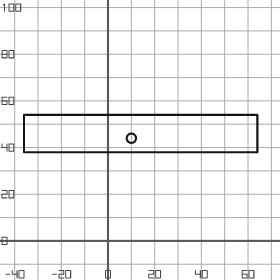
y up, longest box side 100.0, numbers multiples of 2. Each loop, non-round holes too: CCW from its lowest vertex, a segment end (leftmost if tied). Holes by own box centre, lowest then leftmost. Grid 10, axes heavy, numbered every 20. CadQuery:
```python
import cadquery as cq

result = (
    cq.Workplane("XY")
    .moveTo(-36.0, 38.0)
    .lineTo(64.0, 38.0)
    .lineTo(64.0, 54.0)
    .lineTo(-36.0, 54.0)
    .close()
    .moveTo(10.0, 44.0)
    .circle(2.0)
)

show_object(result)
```